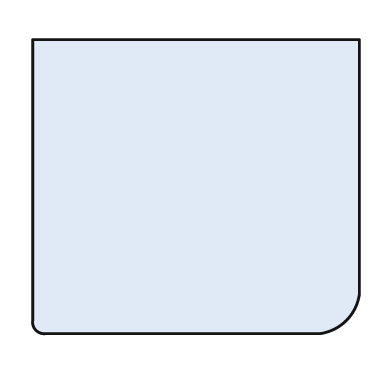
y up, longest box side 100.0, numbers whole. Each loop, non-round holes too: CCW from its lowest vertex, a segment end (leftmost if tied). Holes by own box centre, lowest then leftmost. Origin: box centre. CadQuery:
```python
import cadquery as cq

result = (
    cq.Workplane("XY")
    .moveTo(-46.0, -45.0)
    .lineTo(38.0, -45.0)
    .threePointArc((46.0, -41.0), (50.0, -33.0))
    .lineTo(50.0, 45.0)
    .lineTo(-50.0, 45.0)
    .lineTo(-50.0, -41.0)
    .threePointArc((-49.0, -44.0), (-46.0, -45.0))
    .close()
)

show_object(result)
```